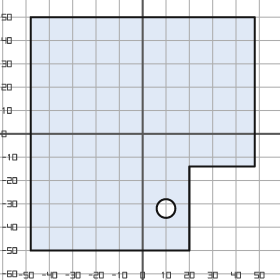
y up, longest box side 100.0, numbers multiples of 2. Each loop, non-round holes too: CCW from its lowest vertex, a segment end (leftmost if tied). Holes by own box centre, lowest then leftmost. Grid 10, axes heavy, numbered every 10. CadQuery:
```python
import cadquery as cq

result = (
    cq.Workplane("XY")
    .moveTo(-48.0, -50.0)
    .lineTo(20.0, -50.0)
    .lineTo(20.0, -14.0)
    .lineTo(48.0, -14.0)
    .lineTo(48.0, 50.0)
    .lineTo(-48.0, 50.0)
    .close()
    .moveTo(10.0, -32.0)
    .circle(4.0)
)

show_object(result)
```